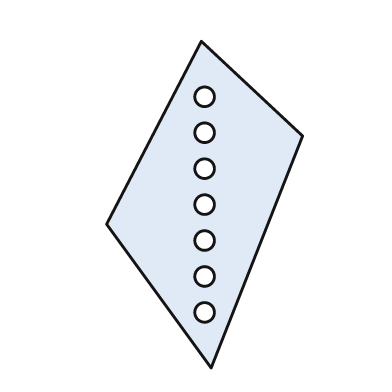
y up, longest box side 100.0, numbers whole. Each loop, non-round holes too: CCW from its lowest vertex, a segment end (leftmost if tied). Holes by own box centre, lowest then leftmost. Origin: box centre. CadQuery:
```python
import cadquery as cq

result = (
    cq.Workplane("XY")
    .moveTo(2.0, -50.0)
    .lineTo(30.0, 21.0)
    .lineTo(-1.0, 50.0)
    .lineTo(-30.0, -6.0)
    .close()
    .moveTo(0.0, -33.0)
    .circle(3.0)
    .moveTo(0.0, -22.0)
    .circle(3.0)
    .moveTo(0.0, -11.0)
    .circle(3.0)
    .moveTo(0.0, 0.0)
    .circle(3.0)
    .moveTo(0.0, 11.0)
    .circle(3.0)
    .moveTo(0.0, 22.0)
    .circle(3.0)
    .moveTo(0.0, 33.0)
    .circle(3.0)
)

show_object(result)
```